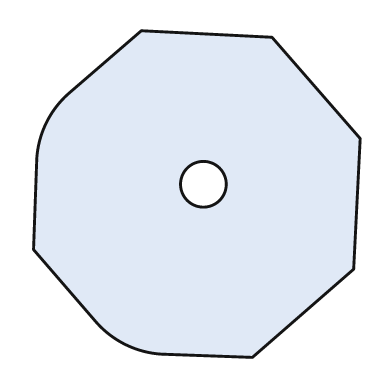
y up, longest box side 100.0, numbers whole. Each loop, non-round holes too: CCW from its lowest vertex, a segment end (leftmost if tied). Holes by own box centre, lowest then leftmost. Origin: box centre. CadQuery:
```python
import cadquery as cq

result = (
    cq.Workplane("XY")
    .moveTo(17.0, -50.0)
    .lineTo(48.0, -23.0)
    .lineTo(50.0, 17.0)
    .lineTo(23.0, 48.0)
    .lineTo(-17.0, 50.0)
    .lineTo(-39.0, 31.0)
    .threePointArc((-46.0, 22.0), (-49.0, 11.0))
    .lineTo(-50.0, -17.0)
    .lineTo(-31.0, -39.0)
    .threePointArc((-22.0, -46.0), (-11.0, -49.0))
    .close()
    .moveTo(2.0, 3.0)
    .circle(7.0)
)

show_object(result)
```